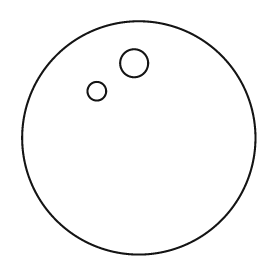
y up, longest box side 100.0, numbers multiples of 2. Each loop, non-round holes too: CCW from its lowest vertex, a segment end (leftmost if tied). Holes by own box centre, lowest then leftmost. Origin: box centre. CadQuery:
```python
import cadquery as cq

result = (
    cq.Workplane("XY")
    .moveTo(0.0, 0.0)
    .circle(50.0)
    .moveTo(-18.0, 20.0)
    .circle(4.0)
    .moveTo(-2.0, 32.0)
    .circle(6.0)
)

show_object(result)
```